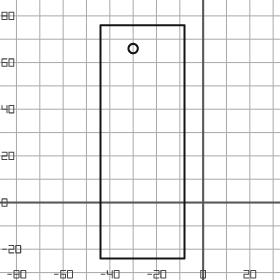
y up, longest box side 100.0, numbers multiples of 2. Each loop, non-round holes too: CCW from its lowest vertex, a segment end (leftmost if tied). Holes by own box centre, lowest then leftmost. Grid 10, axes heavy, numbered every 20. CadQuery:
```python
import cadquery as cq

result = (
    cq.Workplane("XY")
    .moveTo(-44.0, -24.0)
    .lineTo(-8.0, -24.0)
    .lineTo(-8.0, 76.0)
    .lineTo(-44.0, 76.0)
    .close()
    .moveTo(-30.0, 66.0)
    .circle(2.0)
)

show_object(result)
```